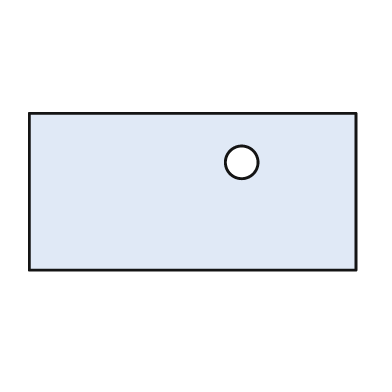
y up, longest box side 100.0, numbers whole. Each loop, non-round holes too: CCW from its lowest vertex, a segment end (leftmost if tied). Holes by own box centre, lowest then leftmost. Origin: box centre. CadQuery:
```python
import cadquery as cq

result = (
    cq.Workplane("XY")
    .moveTo(-50.0, -24.0)
    .lineTo(50.0, -24.0)
    .lineTo(50.0, 24.0)
    .lineTo(-50.0, 24.0)
    .close()
    .moveTo(15.0, 9.0)
    .circle(5.0)
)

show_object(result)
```